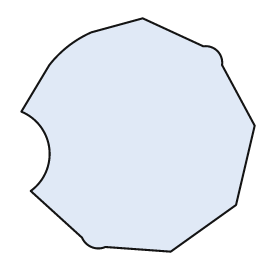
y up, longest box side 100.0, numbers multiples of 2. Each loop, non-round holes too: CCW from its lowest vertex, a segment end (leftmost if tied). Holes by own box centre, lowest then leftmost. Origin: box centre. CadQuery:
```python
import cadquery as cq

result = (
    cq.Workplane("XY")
    .moveTo(14.0, -50.0)
    .lineTo(42.0, -30.0)
    .lineTo(50.0, 4.0)
    .lineTo(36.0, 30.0)
    .threePointArc((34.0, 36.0), (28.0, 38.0))
    .lineTo(2.0, 50.0)
    .lineTo(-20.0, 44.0)
    .threePointArc((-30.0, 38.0), (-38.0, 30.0))
    .lineTo(-50.0, 10.0)
    .threePointArc((-38.0, -6.0), (-46.0, -24.0))
    .lineTo(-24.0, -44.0)
    .threePointArc((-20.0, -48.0), (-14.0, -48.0))
    .close()
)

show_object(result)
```